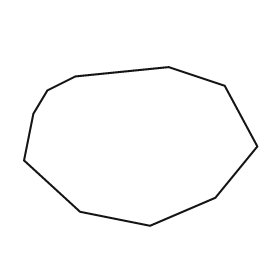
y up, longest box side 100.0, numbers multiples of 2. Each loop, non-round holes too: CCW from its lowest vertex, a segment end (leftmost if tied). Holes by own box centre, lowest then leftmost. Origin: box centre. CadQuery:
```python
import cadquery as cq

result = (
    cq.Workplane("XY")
    .moveTo(4.0, -34.0)
    .lineTo(32.0, -22.0)
    .lineTo(50.0, 0.0)
    .lineTo(36.0, 26.0)
    .lineTo(12.0, 34.0)
    .lineTo(-28.0, 30.0)
    .lineTo(-40.0, 24.0)
    .lineTo(-46.0, 14.0)
    .lineTo(-50.0, -6.0)
    .lineTo(-26.0, -28.0)
    .close()
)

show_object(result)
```